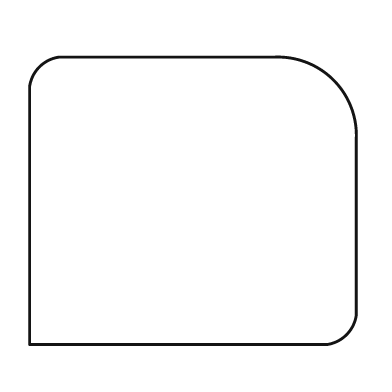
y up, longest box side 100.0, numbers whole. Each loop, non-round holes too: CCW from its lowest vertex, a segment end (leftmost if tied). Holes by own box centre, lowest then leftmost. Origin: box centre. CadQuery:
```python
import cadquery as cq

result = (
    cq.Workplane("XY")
    .moveTo(-50.0, -44.0)
    .lineTo(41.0, -44.0)
    .threePointArc((47.0, -41.0), (50.0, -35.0))
    .lineTo(50.0, 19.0)
    .threePointArc((43.0, 37.0), (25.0, 44.0))
    .lineTo(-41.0, 44.0)
    .threePointArc((-47.0, 41.0), (-50.0, 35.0))
    .close()
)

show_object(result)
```